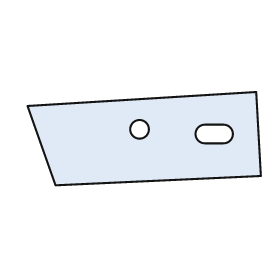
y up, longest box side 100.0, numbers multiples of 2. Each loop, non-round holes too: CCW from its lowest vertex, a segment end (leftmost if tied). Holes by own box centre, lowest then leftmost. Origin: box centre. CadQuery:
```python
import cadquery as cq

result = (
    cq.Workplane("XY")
    .moveTo(-38.0, -20.0)
    .lineTo(50.0, -16.0)
    .lineTo(48.0, 20.0)
    .lineTo(-50.0, 14.0)
    .close()
    .moveTo(26.0, -2.0)
    .lineTo(34.0, -2.0)
    .threePointArc((38.0, 2.0), (34.0, 6.0))
    .lineTo(26.0, 6.0)
    .threePointArc((22.0, 2.0), (26.0, -2.0))
    .close()
    .moveTo(-2.0, 4.0)
    .circle(4.0)
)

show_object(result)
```